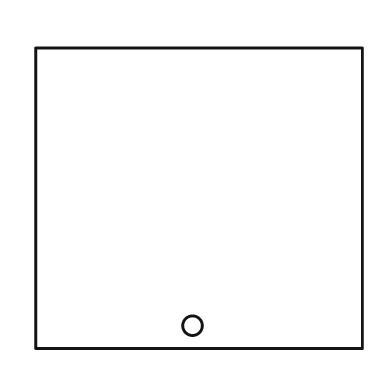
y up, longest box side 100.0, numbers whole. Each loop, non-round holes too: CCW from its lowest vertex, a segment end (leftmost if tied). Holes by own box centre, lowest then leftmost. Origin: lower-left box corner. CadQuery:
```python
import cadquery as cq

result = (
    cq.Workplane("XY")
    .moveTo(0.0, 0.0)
    .lineTo(100.0, 0.0)
    .lineTo(100.0, 92.0)
    .lineTo(0.0, 92.0)
    .close()
    .moveTo(48.0, 7.0)
    .circle(3.0)
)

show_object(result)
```